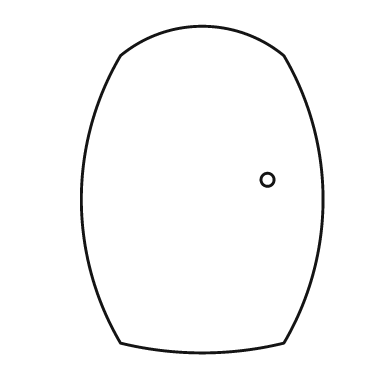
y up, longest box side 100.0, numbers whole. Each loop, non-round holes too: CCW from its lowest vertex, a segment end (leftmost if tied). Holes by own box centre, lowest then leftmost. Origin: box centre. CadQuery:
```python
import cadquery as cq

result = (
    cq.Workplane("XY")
    .moveTo(-25.0, -47.0)
    .threePointArc((0.0, -50.0), (25.0, -47.0))
    .threePointArc((37.0, -3.0), (25.0, 41.0))
    .threePointArc((0.0, 50.0), (-25.0, 41.0))
    .threePointArc((-37.0, -3.0), (-25.0, -47.0))
    .close()
    .moveTo(20.0, 3.0)
    .circle(2.0)
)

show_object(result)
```